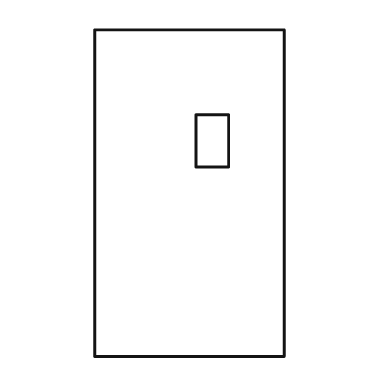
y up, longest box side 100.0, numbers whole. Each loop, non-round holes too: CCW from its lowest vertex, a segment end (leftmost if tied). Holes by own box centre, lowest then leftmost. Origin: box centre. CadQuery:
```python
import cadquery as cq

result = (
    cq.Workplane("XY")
    .moveTo(-29.0, -50.0)
    .lineTo(29.0, -50.0)
    .lineTo(29.0, 50.0)
    .lineTo(-29.0, 50.0)
    .close()
    .moveTo(2.0, 8.0)
    .lineTo(12.0, 8.0)
    .lineTo(12.0, 24.0)
    .lineTo(2.0, 24.0)
    .close()
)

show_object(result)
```